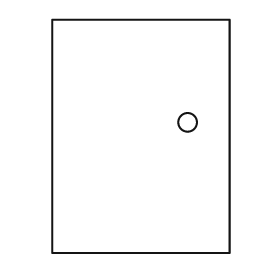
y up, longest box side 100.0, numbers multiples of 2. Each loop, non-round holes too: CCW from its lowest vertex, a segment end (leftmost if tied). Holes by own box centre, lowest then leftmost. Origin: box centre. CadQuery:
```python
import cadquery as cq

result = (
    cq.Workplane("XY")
    .moveTo(-38.0, -50.0)
    .lineTo(38.0, -50.0)
    .lineTo(38.0, 50.0)
    .lineTo(-38.0, 50.0)
    .close()
    .moveTo(20.0, 6.0)
    .circle(4.0)
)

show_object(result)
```